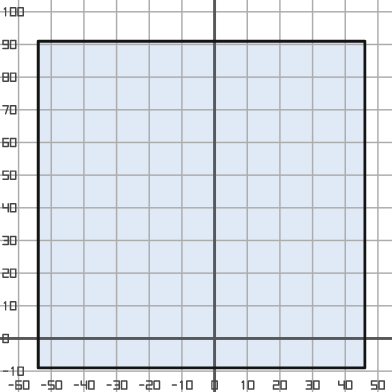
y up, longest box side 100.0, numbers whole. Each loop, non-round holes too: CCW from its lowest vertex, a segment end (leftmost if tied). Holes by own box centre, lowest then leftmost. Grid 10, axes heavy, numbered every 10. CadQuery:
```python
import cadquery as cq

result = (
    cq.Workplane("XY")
    .moveTo(-54.0, -9.0)
    .lineTo(46.0, -9.0)
    .lineTo(46.0, 91.0)
    .lineTo(-54.0, 91.0)
    .close()
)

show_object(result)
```